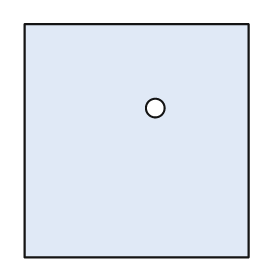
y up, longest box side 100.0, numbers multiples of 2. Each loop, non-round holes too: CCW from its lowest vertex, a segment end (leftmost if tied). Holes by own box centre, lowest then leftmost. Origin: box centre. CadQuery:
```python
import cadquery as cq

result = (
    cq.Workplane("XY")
    .moveTo(-48.0, -50.0)
    .lineTo(48.0, -50.0)
    .lineTo(48.0, 50.0)
    .lineTo(-48.0, 50.0)
    .close()
    .moveTo(8.0, 14.0)
    .circle(4.0)
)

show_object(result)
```